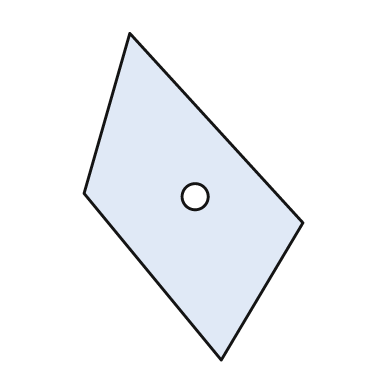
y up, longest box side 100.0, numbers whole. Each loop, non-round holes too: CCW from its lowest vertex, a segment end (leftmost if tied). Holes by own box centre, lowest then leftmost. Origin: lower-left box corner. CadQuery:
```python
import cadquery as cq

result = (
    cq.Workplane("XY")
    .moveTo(42.0, 0.0)
    .lineTo(67.0, 42.0)
    .lineTo(14.0, 100.0)
    .lineTo(0.0, 51.0)
    .close()
    .moveTo(34.0, 50.0)
    .circle(4.0)
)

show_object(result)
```